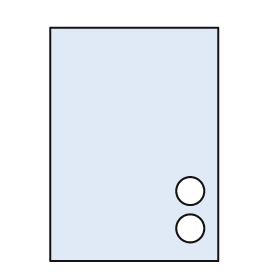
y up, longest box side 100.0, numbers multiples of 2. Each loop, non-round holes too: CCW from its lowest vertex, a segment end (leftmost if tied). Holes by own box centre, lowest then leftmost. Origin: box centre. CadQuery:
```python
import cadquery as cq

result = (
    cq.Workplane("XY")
    .moveTo(-36.0, -50.0)
    .lineTo(36.0, -50.0)
    .lineTo(36.0, 50.0)
    .lineTo(-36.0, 50.0)
    .close()
    .moveTo(24.0, -36.0)
    .circle(6.0)
    .moveTo(24.0, -20.0)
    .circle(6.0)
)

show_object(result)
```